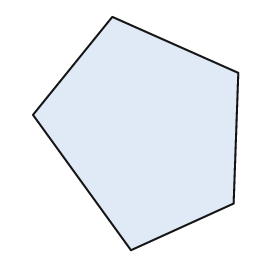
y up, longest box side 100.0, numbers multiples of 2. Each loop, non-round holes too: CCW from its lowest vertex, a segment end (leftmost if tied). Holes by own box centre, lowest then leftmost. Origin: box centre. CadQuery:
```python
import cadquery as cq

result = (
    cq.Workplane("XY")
    .moveTo(-2.0, -50.0)
    .lineTo(42.0, -30.0)
    .lineTo(44.0, 26.0)
    .lineTo(-10.0, 50.0)
    .lineTo(-44.0, 8.0)
    .close()
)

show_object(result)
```